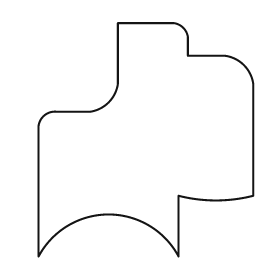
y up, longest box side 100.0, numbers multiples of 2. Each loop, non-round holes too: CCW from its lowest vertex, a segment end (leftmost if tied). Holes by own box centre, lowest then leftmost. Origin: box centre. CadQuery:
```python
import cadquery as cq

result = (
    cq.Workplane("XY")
    .moveTo(-46.0, -50.0)
    .threePointArc((-16.0, -32.0), (14.0, -50.0))
    .lineTo(14.0, -24.0)
    .threePointArc((30.0, -26.0), (46.0, -24.0))
    .lineTo(46.0, 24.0)
    .threePointArc((42.0, 32.0), (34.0, 36.0))
    .lineTo(18.0, 36.0)
    .lineTo(18.0, 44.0)
    .threePointArc((16.0, 48.0), (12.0, 50.0))
    .lineTo(-12.0, 50.0)
    .lineTo(-12.0, 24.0)
    .threePointArc((-16.0, 16.0), (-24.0, 12.0))
    .lineTo(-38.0, 12.0)
    .threePointArc((-44.0, 10.0), (-46.0, 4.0))
    .close()
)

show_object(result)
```